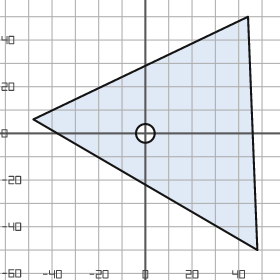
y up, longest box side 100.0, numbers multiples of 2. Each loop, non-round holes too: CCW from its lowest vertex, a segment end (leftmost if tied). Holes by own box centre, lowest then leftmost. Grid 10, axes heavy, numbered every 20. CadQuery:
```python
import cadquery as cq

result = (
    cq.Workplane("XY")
    .moveTo(48.0, -50.0)
    .lineTo(44.0, 50.0)
    .lineTo(-48.0, 6.0)
    .close()
    .moveTo(0.0, 0.0)
    .circle(4.0)
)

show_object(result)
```